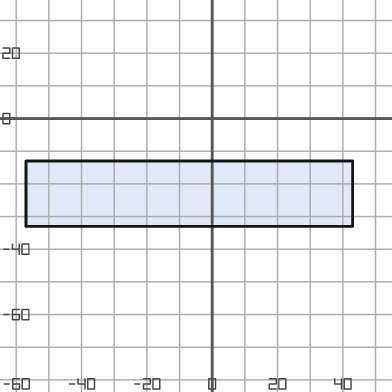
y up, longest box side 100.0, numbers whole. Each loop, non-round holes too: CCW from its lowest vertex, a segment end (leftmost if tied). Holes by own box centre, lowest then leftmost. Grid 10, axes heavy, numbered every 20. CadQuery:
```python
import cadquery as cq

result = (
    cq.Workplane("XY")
    .moveTo(-57.0, -33.0)
    .lineTo(43.0, -33.0)
    .lineTo(43.0, -13.0)
    .lineTo(-57.0, -13.0)
    .close()
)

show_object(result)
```